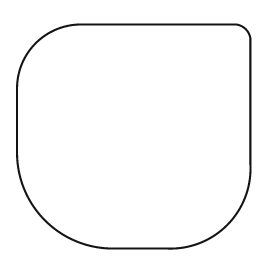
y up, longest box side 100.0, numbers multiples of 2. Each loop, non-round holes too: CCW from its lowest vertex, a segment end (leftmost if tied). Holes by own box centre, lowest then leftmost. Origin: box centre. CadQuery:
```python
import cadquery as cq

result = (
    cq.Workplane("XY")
    .moveTo(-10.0, -48.0)
    .lineTo(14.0, -48.0)
    .threePointArc((40.0, -38.0), (50.0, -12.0))
    .lineTo(50.0, 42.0)
    .threePointArc((48.0, 46.0), (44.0, 48.0))
    .lineTo(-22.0, 48.0)
    .threePointArc((-42.0, 40.0), (-50.0, 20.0))
    .lineTo(-50.0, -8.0)
    .threePointArc((-38.0, -36.0), (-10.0, -48.0))
    .close()
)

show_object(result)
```